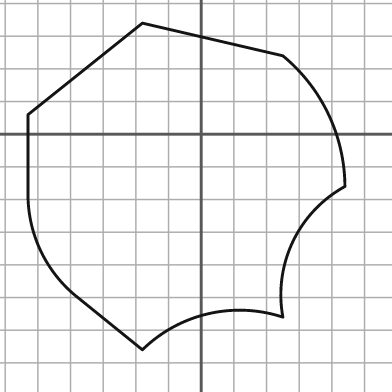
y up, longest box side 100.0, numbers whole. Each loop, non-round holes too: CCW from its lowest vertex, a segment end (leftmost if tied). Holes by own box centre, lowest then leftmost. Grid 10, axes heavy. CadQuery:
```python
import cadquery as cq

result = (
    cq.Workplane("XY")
    .moveTo(-18.0, -66.0)
    .threePointArc((2.0, -55.0), (25.0, -56.0))
    .threePointArc((28.0, -33.0), (44.0, -16.0))
    .threePointArc((39.0, 6.0), (25.0, 24.0))
    .lineTo(-18.0, 34.0)
    .lineTo(-53.0, 6.0)
    .lineTo(-53.0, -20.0)
    .threePointArc((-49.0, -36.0), (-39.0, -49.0))
    .close()
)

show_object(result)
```